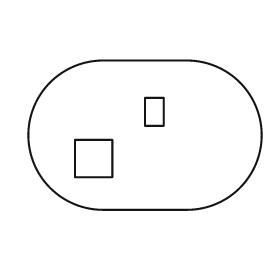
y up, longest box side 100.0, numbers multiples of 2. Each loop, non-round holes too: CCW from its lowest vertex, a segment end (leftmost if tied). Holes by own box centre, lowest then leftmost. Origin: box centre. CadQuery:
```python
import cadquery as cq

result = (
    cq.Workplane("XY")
    .moveTo(-18.0, -32.0)
    .lineTo(18.0, -32.0)
    .threePointArc((50.0, 0.0), (18.0, 32.0))
    .lineTo(-18.0, 32.0)
    .threePointArc((-50.0, 0.0), (-18.0, -32.0))
    .close()
    .moveTo(-30.0, -18.0)
    .lineTo(-14.0, -18.0)
    .lineTo(-14.0, -2.0)
    .lineTo(-30.0, -2.0)
    .close()
    .moveTo(0.0, 4.0)
    .lineTo(8.0, 4.0)
    .lineTo(8.0, 16.0)
    .lineTo(0.0, 16.0)
    .close()
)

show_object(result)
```